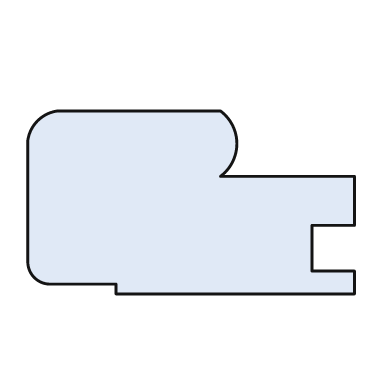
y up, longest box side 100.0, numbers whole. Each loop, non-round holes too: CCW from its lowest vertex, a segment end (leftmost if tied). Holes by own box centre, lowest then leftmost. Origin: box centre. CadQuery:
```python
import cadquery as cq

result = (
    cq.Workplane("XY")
    .moveTo(-23.0, -28.0)
    .lineTo(50.0, -28.0)
    .lineTo(50.0, -21.0)
    .lineTo(37.0, -21.0)
    .lineTo(37.0, -7.0)
    .lineTo(50.0, -7.0)
    .lineTo(50.0, 8.0)
    .lineTo(9.0, 8.0)
    .threePointArc((14.0, 18.0), (9.0, 28.0))
    .lineTo(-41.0, 28.0)
    .threePointArc((-47.0, 25.0), (-50.0, 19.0))
    .lineTo(-50.0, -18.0)
    .threePointArc((-48.0, -23.0), (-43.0, -25.0))
    .lineTo(-23.0, -25.0)
    .close()
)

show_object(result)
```